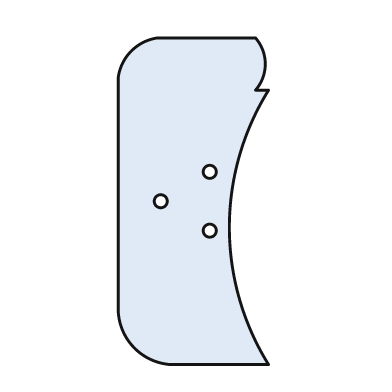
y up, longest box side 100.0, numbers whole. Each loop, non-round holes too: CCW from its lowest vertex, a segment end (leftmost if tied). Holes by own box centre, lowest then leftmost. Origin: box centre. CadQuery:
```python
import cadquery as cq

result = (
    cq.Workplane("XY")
    .moveTo(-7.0, -50.0)
    .lineTo(23.0, -50.0)
    .threePointArc((11.0, -8.0), (23.0, 34.0))
    .lineTo(19.0, 34.0)
    .threePointArc((22.0, 42.0), (19.0, 50.0))
    .lineTo(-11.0, 50.0)
    .threePointArc((-19.0, 46.0), (-23.0, 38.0))
    .lineTo(-23.0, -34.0)
    .threePointArc((-18.0, -45.0), (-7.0, -50.0))
    .close()
    .moveTo(5.0, -9.0)
    .circle(2.0)
    .moveTo(-10.0, 0.0)
    .circle(2.0)
    .moveTo(5.0, 9.0)
    .circle(2.0)
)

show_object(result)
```